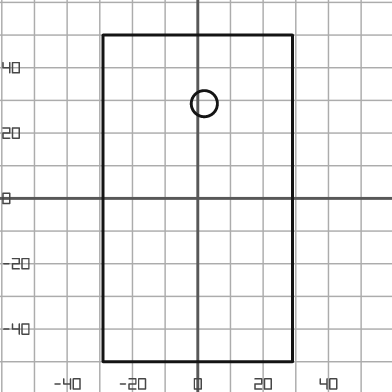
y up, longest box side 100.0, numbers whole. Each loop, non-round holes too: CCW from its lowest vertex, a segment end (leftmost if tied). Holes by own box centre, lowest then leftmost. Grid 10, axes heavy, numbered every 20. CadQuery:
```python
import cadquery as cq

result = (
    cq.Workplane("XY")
    .moveTo(-29.0, -50.0)
    .lineTo(29.0, -50.0)
    .lineTo(29.0, 50.0)
    .lineTo(-29.0, 50.0)
    .close()
    .moveTo(2.0, 29.0)
    .circle(4.0)
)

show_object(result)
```